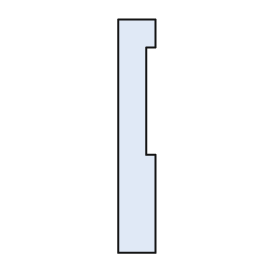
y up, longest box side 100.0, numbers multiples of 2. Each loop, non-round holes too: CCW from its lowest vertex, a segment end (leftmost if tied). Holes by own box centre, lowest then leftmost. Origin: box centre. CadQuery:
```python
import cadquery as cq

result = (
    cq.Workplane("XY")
    .moveTo(-8.0, -50.0)
    .lineTo(8.0, -50.0)
    .lineTo(8.0, -8.0)
    .lineTo(4.0, -8.0)
    .lineTo(4.0, 38.0)
    .lineTo(8.0, 38.0)
    .lineTo(8.0, 50.0)
    .lineTo(-8.0, 50.0)
    .close()
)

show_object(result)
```